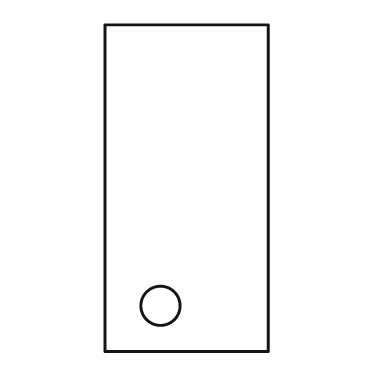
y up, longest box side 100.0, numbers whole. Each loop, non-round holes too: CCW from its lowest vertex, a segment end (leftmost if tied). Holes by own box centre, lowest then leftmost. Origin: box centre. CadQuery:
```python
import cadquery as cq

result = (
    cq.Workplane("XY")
    .moveTo(-25.0, -50.0)
    .lineTo(25.0, -50.0)
    .lineTo(25.0, 50.0)
    .lineTo(-25.0, 50.0)
    .close()
    .moveTo(-8.0, -36.0)
    .circle(6.0)
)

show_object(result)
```